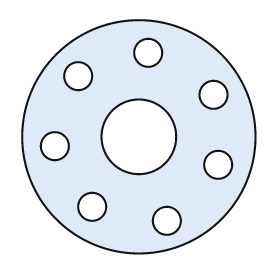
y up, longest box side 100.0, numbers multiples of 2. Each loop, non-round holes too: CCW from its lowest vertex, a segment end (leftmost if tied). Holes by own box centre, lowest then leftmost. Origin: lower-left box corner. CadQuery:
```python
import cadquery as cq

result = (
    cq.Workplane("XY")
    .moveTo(50.0, 50.0)
    .circle(50.0)
    .moveTo(62.0, 14.0)
    .circle(6.0)
    .moveTo(30.0, 20.0)
    .circle(6.0)
    .moveTo(84.0, 38.0)
    .circle(6.0)
    .moveTo(14.0, 46.0)
    .circle(6.0)
    .moveTo(50.0, 50.0)
    .circle(16.0)
    .moveTo(82.0, 68.0)
    .circle(6.0)
    .moveTo(24.0, 76.0)
    .circle(6.0)
    .moveTo(54.0, 86.0)
    .circle(6.0)
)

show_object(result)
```